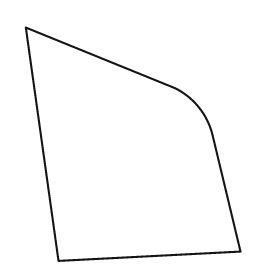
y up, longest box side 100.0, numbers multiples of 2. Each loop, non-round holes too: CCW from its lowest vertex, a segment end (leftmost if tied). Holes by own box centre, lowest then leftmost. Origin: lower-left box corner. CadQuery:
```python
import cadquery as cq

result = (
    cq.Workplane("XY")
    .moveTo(14.0, 0.0)
    .lineTo(92.0, 4.0)
    .lineTo(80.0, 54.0)
    .threePointArc((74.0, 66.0), (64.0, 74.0))
    .lineTo(0.0, 100.0)
    .close()
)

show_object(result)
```